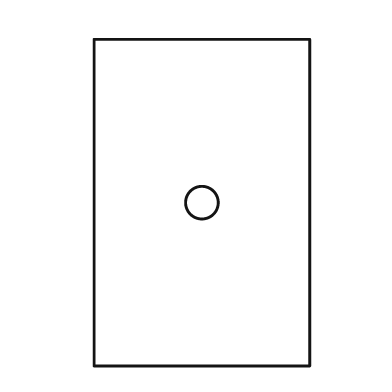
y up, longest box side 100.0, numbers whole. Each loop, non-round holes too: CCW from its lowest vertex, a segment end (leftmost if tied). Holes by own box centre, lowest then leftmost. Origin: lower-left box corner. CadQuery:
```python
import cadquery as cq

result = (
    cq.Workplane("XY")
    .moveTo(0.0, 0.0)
    .lineTo(66.0, 0.0)
    .lineTo(66.0, 100.0)
    .lineTo(0.0, 100.0)
    .close()
    .moveTo(33.0, 50.0)
    .circle(5.0)
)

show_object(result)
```